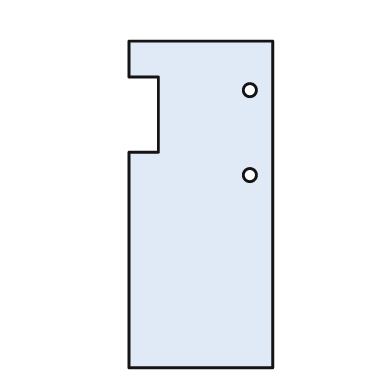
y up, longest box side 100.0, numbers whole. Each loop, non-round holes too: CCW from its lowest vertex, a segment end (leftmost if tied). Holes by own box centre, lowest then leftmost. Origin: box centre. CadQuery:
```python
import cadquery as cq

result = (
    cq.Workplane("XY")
    .moveTo(-22.0, -50.0)
    .lineTo(22.0, -50.0)
    .lineTo(22.0, 50.0)
    .lineTo(-22.0, 50.0)
    .lineTo(-22.0, 39.0)
    .lineTo(-13.0, 39.0)
    .lineTo(-13.0, 16.0)
    .lineTo(-22.0, 16.0)
    .close()
    .moveTo(15.0, 9.0)
    .circle(2.0)
    .moveTo(15.0, 35.0)
    .circle(2.0)
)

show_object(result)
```